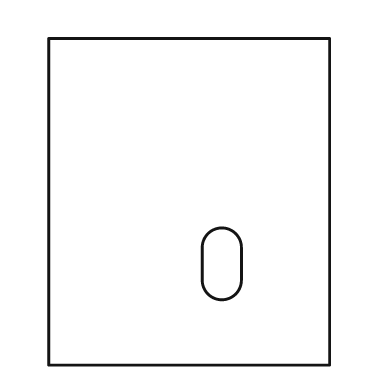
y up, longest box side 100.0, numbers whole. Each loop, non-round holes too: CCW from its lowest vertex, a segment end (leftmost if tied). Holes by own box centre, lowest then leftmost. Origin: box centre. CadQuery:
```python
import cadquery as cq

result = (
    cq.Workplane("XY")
    .moveTo(-43.0, -50.0)
    .lineTo(43.0, -50.0)
    .lineTo(43.0, 50.0)
    .lineTo(-43.0, 50.0)
    .close()
    .moveTo(4.0, -24.0)
    .threePointArc((10.0, -30.0), (16.0, -24.0))
    .lineTo(16.0, -14.0)
    .threePointArc((10.0, -8.0), (4.0, -14.0))
    .close()
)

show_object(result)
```